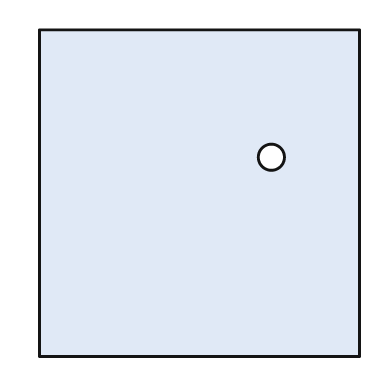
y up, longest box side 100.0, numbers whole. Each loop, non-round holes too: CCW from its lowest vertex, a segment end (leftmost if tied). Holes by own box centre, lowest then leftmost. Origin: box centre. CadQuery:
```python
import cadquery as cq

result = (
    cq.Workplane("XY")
    .moveTo(-49.0, -50.0)
    .lineTo(49.0, -50.0)
    .lineTo(49.0, 50.0)
    .lineTo(-49.0, 50.0)
    .close()
    .moveTo(22.0, 11.0)
    .circle(4.0)
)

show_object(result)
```